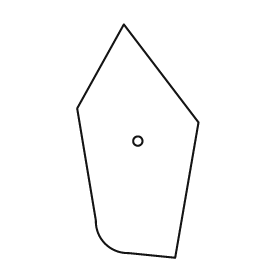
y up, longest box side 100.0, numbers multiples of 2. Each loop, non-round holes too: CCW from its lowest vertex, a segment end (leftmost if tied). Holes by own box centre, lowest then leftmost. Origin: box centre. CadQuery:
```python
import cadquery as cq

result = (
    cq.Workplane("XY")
    .moveTo(16.0, -50.0)
    .lineTo(26.0, 8.0)
    .lineTo(-6.0, 50.0)
    .lineTo(-26.0, 14.0)
    .lineTo(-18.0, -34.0)
    .threePointArc((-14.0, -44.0), (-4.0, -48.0))
    .close()
    .moveTo(0.0, 0.0)
    .circle(2.0)
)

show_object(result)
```